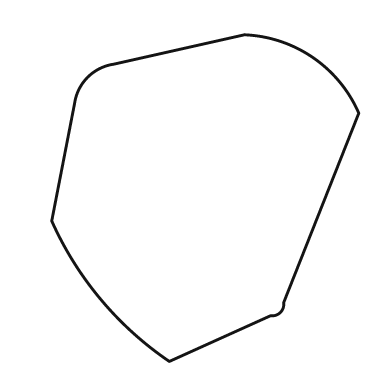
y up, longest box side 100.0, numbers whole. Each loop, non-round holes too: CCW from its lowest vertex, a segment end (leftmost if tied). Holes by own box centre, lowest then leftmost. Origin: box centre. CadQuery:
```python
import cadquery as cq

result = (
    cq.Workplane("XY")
    .moveTo(-11.0, -50.0)
    .lineTo(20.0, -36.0)
    .threePointArc((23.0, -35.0), (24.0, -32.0))
    .lineTo(47.0, 26.0)
    .threePointArc((33.0, 43.0), (12.0, 50.0))
    .lineTo(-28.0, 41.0)
    .threePointArc((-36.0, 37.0), (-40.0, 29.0))
    .lineTo(-47.0, -7.0)
    .threePointArc((-32.0, -31.0), (-11.0, -50.0))
    .close()
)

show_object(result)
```